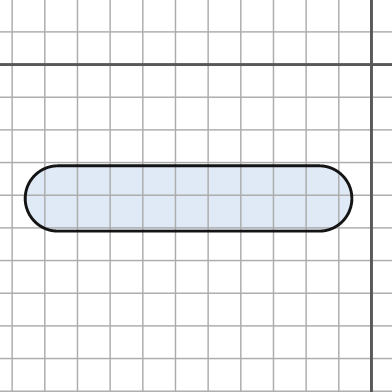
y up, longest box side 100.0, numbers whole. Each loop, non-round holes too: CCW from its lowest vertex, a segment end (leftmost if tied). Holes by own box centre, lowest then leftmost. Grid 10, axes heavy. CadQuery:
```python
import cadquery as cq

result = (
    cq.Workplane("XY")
    .moveTo(-96.0, -51.0)
    .lineTo(-16.0, -51.0)
    .threePointArc((-6.0, -41.0), (-16.0, -31.0))
    .lineTo(-96.0, -31.0)
    .threePointArc((-106.0, -41.0), (-96.0, -51.0))
    .close()
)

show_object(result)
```